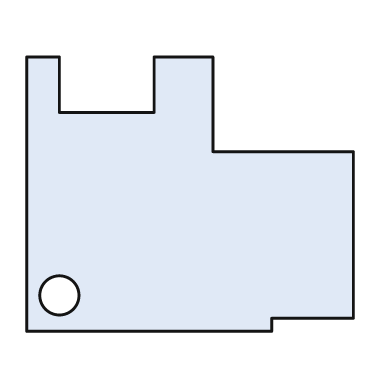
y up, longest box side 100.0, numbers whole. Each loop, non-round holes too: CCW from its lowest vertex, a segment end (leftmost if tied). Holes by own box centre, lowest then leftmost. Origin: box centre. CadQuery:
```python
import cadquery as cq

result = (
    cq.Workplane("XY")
    .moveTo(-50.0, -42.0)
    .lineTo(25.0, -42.0)
    .lineTo(25.0, -38.0)
    .lineTo(50.0, -38.0)
    .lineTo(50.0, 13.0)
    .lineTo(7.0, 13.0)
    .lineTo(7.0, 42.0)
    .lineTo(-11.0, 42.0)
    .lineTo(-11.0, 25.0)
    .lineTo(-40.0, 25.0)
    .lineTo(-40.0, 42.0)
    .lineTo(-50.0, 42.0)
    .close()
    .moveTo(-40.0, -31.0)
    .circle(6.0)
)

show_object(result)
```